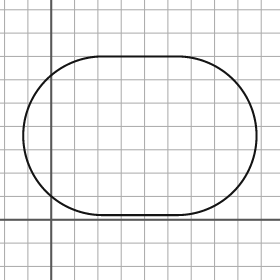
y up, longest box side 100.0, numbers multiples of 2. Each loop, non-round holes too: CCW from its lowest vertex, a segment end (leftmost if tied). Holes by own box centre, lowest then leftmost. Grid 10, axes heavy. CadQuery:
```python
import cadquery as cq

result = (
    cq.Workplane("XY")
    .moveTo(22.0, 2.0)
    .lineTo(54.0, 2.0)
    .threePointArc((88.0, 36.0), (54.0, 70.0))
    .lineTo(22.0, 70.0)
    .threePointArc((-12.0, 36.0), (22.0, 2.0))
    .close()
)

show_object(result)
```